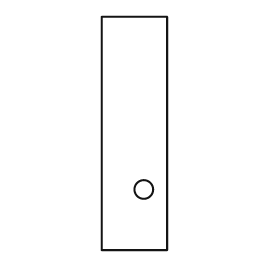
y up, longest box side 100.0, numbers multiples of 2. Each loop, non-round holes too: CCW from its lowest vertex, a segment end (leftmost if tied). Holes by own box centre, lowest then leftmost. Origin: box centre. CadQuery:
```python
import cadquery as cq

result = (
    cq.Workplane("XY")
    .moveTo(-14.0, -50.0)
    .lineTo(14.0, -50.0)
    .lineTo(14.0, 50.0)
    .lineTo(-14.0, 50.0)
    .close()
    .moveTo(4.0, -24.0)
    .circle(4.0)
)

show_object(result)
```